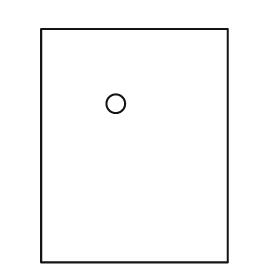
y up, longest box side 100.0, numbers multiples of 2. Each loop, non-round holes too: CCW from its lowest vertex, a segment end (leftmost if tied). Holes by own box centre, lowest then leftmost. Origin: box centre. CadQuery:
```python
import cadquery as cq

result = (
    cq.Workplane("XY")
    .moveTo(-40.0, -50.0)
    .lineTo(40.0, -50.0)
    .lineTo(40.0, 50.0)
    .lineTo(-40.0, 50.0)
    .close()
    .moveTo(-8.0, 18.0)
    .circle(4.0)
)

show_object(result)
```